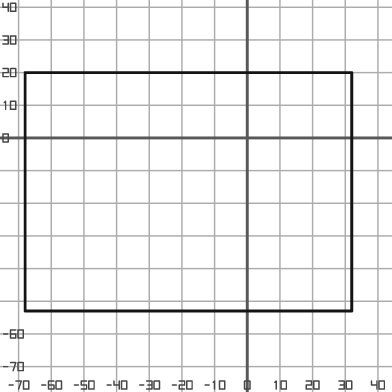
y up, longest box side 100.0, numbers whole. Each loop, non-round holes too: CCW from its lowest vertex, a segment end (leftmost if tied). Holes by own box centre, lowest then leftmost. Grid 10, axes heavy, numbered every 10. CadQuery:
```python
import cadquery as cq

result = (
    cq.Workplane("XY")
    .moveTo(-68.0, -53.0)
    .lineTo(32.0, -53.0)
    .lineTo(32.0, 20.0)
    .lineTo(-68.0, 20.0)
    .close()
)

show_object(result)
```